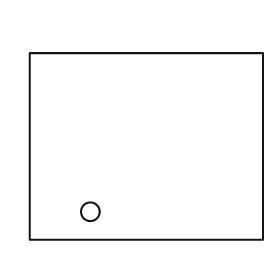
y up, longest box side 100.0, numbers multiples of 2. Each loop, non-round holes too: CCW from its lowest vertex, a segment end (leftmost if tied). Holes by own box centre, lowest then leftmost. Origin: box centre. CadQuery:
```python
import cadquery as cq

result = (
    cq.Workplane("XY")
    .moveTo(-50.0, -40.0)
    .lineTo(50.0, -40.0)
    .lineTo(50.0, 40.0)
    .lineTo(-50.0, 40.0)
    .close()
    .moveTo(-24.0, -28.0)
    .circle(4.0)
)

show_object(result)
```